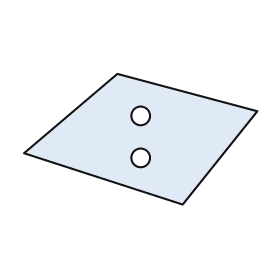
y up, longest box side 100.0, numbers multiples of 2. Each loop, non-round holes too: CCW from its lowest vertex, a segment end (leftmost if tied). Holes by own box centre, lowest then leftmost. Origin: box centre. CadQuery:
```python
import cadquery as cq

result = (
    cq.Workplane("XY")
    .moveTo(18.0, -28.0)
    .lineTo(50.0, 12.0)
    .lineTo(-10.0, 28.0)
    .lineTo(-50.0, -6.0)
    .close()
    .moveTo(0.0, -8.0)
    .circle(4.0)
    .moveTo(0.0, 10.0)
    .circle(4.0)
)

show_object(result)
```